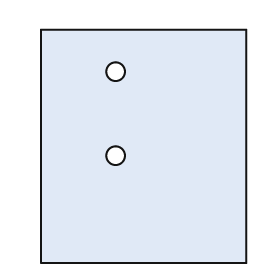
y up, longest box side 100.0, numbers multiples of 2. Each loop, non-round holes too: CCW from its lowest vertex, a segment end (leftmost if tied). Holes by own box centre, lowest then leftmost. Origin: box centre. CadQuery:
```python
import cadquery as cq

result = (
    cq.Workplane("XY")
    .moveTo(-44.0, -50.0)
    .lineTo(44.0, -50.0)
    .lineTo(44.0, 50.0)
    .lineTo(-44.0, 50.0)
    .close()
    .moveTo(-12.0, -4.0)
    .circle(4.0)
    .moveTo(-12.0, 32.0)
    .circle(4.0)
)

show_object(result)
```